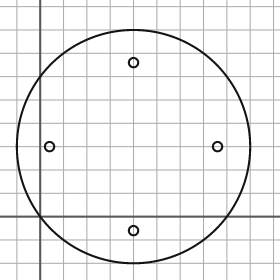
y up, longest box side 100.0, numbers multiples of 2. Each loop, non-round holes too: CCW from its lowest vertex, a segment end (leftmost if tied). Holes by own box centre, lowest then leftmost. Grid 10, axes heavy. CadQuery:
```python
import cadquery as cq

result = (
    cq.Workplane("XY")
    .moveTo(40.0, 30.0)
    .circle(50.0)
    .moveTo(40.0, -6.0)
    .circle(2.0)
    .moveTo(4.0, 30.0)
    .circle(2.0)
    .moveTo(76.0, 30.0)
    .circle(2.0)
    .moveTo(40.0, 66.0)
    .circle(2.0)
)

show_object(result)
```